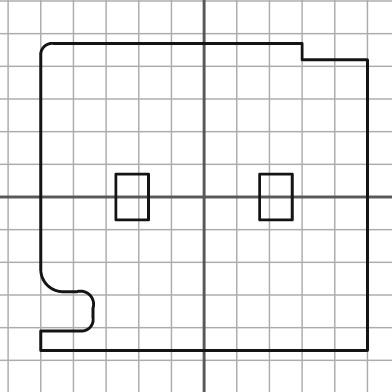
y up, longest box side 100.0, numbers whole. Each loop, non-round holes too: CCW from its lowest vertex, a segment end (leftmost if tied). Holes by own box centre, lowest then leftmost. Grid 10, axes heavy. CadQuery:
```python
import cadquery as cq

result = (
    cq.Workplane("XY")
    .moveTo(-50.0, -47.0)
    .lineTo(50.0, -47.0)
    .lineTo(50.0, 42.0)
    .lineTo(30.0, 42.0)
    .lineTo(30.0, 47.0)
    .lineTo(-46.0, 47.0)
    .threePointArc((-49.0, 46.0), (-50.0, 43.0))
    .lineTo(-50.0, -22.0)
    .threePointArc((-48.0, -27.0), (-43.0, -29.0))
    .lineTo(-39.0, -29.0)
    .threePointArc((-35.0, -30.0), (-34.0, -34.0))
    .lineTo(-34.0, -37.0)
    .threePointArc((-35.0, -40.0), (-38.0, -41.0))
    .lineTo(-50.0, -41.0)
    .close()
    .moveTo(-27.0, -7.0)
    .lineTo(-17.0, -7.0)
    .lineTo(-17.0, 7.0)
    .lineTo(-27.0, 7.0)
    .close()
    .moveTo(17.0, -7.0)
    .lineTo(27.0, -7.0)
    .lineTo(27.0, 7.0)
    .lineTo(17.0, 7.0)
    .close()
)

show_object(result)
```